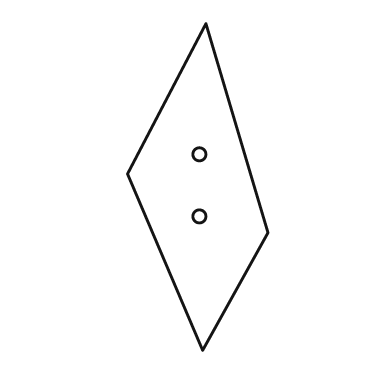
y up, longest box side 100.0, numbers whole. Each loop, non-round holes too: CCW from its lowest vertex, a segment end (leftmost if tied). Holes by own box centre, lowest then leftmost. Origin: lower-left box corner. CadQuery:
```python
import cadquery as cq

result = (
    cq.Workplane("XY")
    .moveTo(23.0, 0.0)
    .lineTo(43.0, 36.0)
    .lineTo(24.0, 100.0)
    .lineTo(0.0, 54.0)
    .close()
    .moveTo(22.0, 41.0)
    .circle(2.0)
    .moveTo(22.0, 60.0)
    .circle(2.0)
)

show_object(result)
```